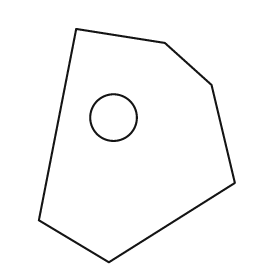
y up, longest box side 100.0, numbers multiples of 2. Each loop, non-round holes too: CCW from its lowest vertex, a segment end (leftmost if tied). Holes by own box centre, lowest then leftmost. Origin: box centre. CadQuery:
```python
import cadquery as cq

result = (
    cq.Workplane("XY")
    .moveTo(-12.0, -50.0)
    .lineTo(42.0, -16.0)
    .lineTo(32.0, 26.0)
    .lineTo(12.0, 44.0)
    .lineTo(-26.0, 50.0)
    .lineTo(-42.0, -32.0)
    .close()
    .moveTo(-10.0, 12.0)
    .circle(10.0)
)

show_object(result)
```